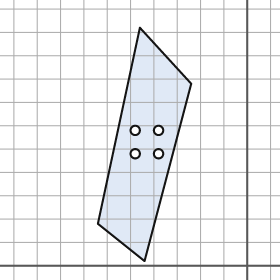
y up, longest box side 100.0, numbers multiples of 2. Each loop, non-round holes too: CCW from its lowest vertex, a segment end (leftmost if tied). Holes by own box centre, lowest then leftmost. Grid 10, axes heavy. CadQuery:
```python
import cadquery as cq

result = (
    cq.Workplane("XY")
    .moveTo(-44.0, 2.0)
    .lineTo(-24.0, 78.0)
    .lineTo(-46.0, 102.0)
    .lineTo(-64.0, 18.0)
    .close()
    .moveTo(-48.0, 48.0)
    .circle(2.0)
    .moveTo(-38.0, 48.0)
    .circle(2.0)
    .moveTo(-48.0, 58.0)
    .circle(2.0)
    .moveTo(-38.0, 58.0)
    .circle(2.0)
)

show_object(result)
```